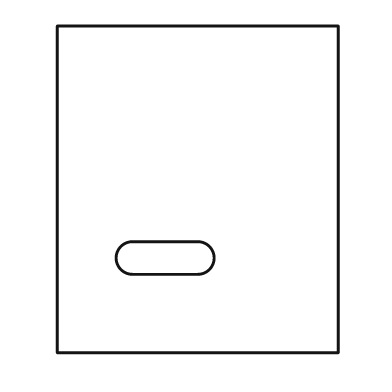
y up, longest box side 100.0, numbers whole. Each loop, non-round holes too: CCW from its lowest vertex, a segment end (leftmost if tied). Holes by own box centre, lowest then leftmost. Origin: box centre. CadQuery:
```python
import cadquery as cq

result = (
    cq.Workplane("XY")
    .moveTo(-43.0, -50.0)
    .lineTo(43.0, -50.0)
    .lineTo(43.0, 50.0)
    .lineTo(-43.0, 50.0)
    .close()
    .moveTo(-20.0, -26.0)
    .lineTo(0.0, -26.0)
    .threePointArc((5.0, -21.0), (0.0, -16.0))
    .lineTo(-20.0, -16.0)
    .threePointArc((-25.0, -21.0), (-20.0, -26.0))
    .close()
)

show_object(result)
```